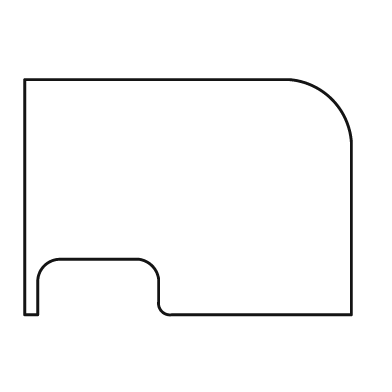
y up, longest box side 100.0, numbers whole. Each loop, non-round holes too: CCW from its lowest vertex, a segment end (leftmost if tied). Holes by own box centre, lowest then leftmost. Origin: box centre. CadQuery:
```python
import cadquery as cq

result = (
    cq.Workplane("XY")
    .moveTo(-50.0, -36.0)
    .lineTo(-46.0, -36.0)
    .lineTo(-46.0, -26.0)
    .threePointArc((-44.0, -21.0), (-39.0, -19.0))
    .lineTo(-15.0, -19.0)
    .threePointArc((-11.0, -21.0), (-9.0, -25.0))
    .lineTo(-9.0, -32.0)
    .threePointArc((-8.0, -35.0), (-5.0, -36.0))
    .lineTo(50.0, -36.0)
    .lineTo(50.0, 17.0)
    .threePointArc((44.0, 30.0), (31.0, 36.0))
    .lineTo(-50.0, 36.0)
    .close()
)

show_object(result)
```